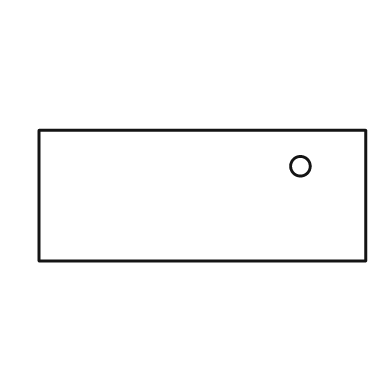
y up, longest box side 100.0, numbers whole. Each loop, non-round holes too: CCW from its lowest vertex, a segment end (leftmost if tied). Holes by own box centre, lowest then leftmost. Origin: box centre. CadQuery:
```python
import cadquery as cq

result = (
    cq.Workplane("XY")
    .moveTo(-50.0, -20.0)
    .lineTo(50.0, -20.0)
    .lineTo(50.0, 20.0)
    .lineTo(-50.0, 20.0)
    .close()
    .moveTo(30.0, 9.0)
    .circle(3.0)
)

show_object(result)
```